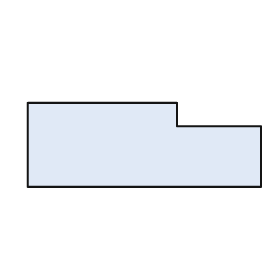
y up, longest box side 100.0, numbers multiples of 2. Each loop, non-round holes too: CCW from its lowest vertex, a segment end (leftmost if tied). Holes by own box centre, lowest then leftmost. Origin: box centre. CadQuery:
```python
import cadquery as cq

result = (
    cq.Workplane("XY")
    .moveTo(-50.0, -18.0)
    .lineTo(50.0, -18.0)
    .lineTo(50.0, 8.0)
    .lineTo(14.0, 8.0)
    .lineTo(14.0, 18.0)
    .lineTo(-50.0, 18.0)
    .close()
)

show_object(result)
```